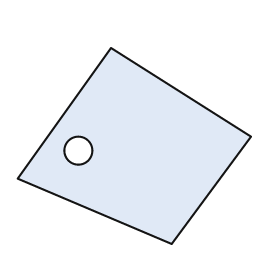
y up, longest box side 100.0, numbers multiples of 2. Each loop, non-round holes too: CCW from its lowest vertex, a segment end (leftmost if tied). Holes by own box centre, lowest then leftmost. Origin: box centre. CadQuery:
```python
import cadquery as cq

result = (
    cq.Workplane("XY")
    .moveTo(16.0, -42.0)
    .lineTo(50.0, 4.0)
    .lineTo(-10.0, 42.0)
    .lineTo(-50.0, -14.0)
    .close()
    .moveTo(-24.0, -2.0)
    .circle(6.0)
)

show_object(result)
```